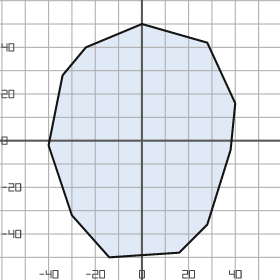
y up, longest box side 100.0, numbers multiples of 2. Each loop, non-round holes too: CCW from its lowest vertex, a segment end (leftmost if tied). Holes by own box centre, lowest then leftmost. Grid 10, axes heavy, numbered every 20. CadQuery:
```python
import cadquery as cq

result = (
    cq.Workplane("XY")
    .moveTo(-14.0, -50.0)
    .lineTo(16.0, -48.0)
    .lineTo(28.0, -36.0)
    .lineTo(38.0, -4.0)
    .lineTo(40.0, 16.0)
    .lineTo(28.0, 42.0)
    .lineTo(0.0, 50.0)
    .lineTo(-24.0, 40.0)
    .lineTo(-34.0, 28.0)
    .lineTo(-40.0, -2.0)
    .lineTo(-30.0, -32.0)
    .close()
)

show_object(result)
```